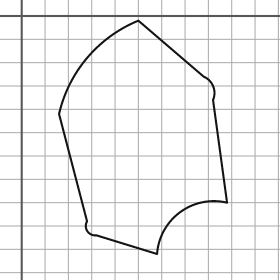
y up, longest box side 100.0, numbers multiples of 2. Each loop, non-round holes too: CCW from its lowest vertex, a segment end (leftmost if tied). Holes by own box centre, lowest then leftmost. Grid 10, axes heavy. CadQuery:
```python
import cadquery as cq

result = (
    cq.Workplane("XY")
    .moveTo(58.0, -102.0)
    .threePointArc((68.0, -84.0), (88.0, -80.0))
    .lineTo(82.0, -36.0)
    .threePointArc((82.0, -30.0), (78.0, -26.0))
    .lineTo(50.0, -2.0)
    .threePointArc((28.0, -18.0), (16.0, -42.0))
    .lineTo(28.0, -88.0)
    .threePointArc((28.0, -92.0), (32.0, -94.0))
    .close()
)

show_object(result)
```